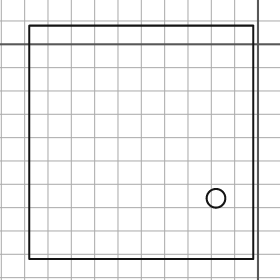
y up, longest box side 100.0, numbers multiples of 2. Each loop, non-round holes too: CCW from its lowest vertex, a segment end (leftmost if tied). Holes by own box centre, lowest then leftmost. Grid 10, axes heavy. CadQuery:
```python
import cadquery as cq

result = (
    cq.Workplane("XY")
    .moveTo(-98.0, -92.0)
    .lineTo(-2.0, -92.0)
    .lineTo(-2.0, 8.0)
    .lineTo(-98.0, 8.0)
    .close()
    .moveTo(-18.0, -66.0)
    .circle(4.0)
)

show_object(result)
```